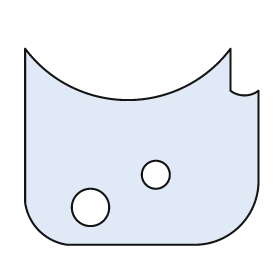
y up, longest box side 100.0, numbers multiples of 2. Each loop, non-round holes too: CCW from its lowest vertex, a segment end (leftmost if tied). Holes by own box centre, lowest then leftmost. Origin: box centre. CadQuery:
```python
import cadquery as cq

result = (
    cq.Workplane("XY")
    .moveTo(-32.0, -42.0)
    .lineTo(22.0, -42.0)
    .threePointArc((42.0, -34.0), (50.0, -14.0))
    .lineTo(50.0, 24.0)
    .threePointArc((44.0, 22.0), (38.0, 24.0))
    .lineTo(38.0, 42.0)
    .threePointArc((-6.0, 20.0), (-50.0, 42.0))
    .lineTo(-50.0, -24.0)
    .threePointArc((-44.0, -36.0), (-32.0, -42.0))
    .close()
    .moveTo(-22.0, -26.0)
    .circle(8.0)
    .moveTo(6.0, -12.0)
    .circle(6.0)
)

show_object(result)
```